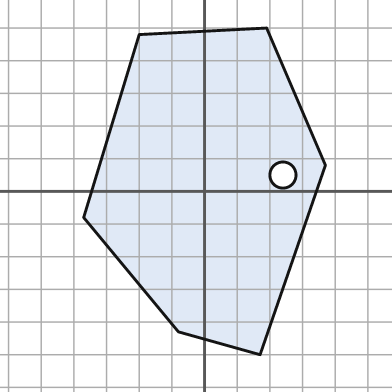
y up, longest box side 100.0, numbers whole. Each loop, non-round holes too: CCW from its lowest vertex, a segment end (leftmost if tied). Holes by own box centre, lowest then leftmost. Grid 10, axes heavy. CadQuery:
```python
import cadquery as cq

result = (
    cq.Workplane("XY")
    .moveTo(17.0, -50.0)
    .lineTo(37.0, 8.0)
    .lineTo(19.0, 50.0)
    .lineTo(-20.0, 48.0)
    .lineTo(-37.0, -8.0)
    .lineTo(-8.0, -43.0)
    .close()
    .moveTo(24.0, 5.0)
    .circle(4.0)
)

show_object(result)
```